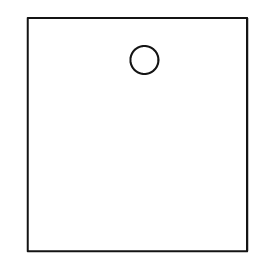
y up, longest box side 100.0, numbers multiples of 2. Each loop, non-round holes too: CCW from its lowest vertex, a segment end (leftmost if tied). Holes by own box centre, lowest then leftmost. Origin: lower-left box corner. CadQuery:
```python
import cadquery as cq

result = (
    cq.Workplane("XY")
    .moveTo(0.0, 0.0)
    .lineTo(94.0, 0.0)
    .lineTo(94.0, 100.0)
    .lineTo(0.0, 100.0)
    .close()
    .moveTo(50.0, 82.0)
    .circle(6.0)
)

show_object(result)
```